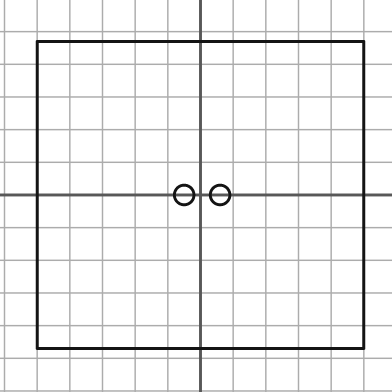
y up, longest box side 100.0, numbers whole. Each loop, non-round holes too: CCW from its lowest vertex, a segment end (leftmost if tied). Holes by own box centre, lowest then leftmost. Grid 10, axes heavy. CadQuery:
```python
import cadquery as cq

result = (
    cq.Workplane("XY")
    .moveTo(-50.0, -47.0)
    .lineTo(50.0, -47.0)
    .lineTo(50.0, 47.0)
    .lineTo(-50.0, 47.0)
    .close()
    .moveTo(-5.0, 0.0)
    .circle(3.0)
    .moveTo(6.0, 0.0)
    .circle(3.0)
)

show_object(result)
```